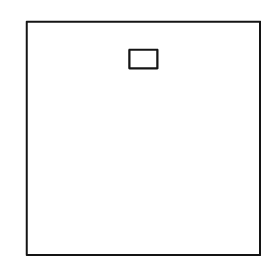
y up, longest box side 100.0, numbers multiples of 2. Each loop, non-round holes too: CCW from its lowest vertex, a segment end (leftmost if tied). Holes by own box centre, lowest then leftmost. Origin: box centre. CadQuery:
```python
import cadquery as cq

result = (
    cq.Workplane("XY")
    .moveTo(-50.0, -50.0)
    .lineTo(50.0, -50.0)
    .lineTo(50.0, 50.0)
    .lineTo(-50.0, 50.0)
    .close()
    .moveTo(-6.0, 30.0)
    .lineTo(6.0, 30.0)
    .lineTo(6.0, 38.0)
    .lineTo(-6.0, 38.0)
    .close()
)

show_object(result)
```